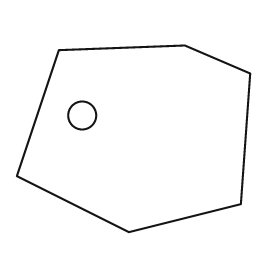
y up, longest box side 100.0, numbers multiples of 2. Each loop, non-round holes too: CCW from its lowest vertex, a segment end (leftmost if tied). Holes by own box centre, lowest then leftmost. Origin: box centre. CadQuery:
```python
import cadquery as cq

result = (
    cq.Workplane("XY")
    .moveTo(-2.0, -40.0)
    .lineTo(46.0, -28.0)
    .lineTo(50.0, 28.0)
    .lineTo(22.0, 40.0)
    .lineTo(-32.0, 38.0)
    .lineTo(-50.0, -16.0)
    .close()
    .moveTo(-22.0, 10.0)
    .circle(6.0)
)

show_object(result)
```